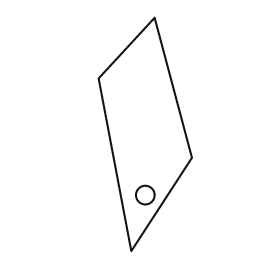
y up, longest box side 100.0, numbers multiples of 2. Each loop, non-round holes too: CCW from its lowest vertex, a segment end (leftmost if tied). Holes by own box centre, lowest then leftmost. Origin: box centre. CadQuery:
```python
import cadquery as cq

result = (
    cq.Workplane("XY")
    .moveTo(-6.0, -50.0)
    .lineTo(20.0, -10.0)
    .lineTo(4.0, 50.0)
    .lineTo(-20.0, 24.0)
    .close()
    .moveTo(0.0, -26.0)
    .circle(4.0)
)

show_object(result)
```